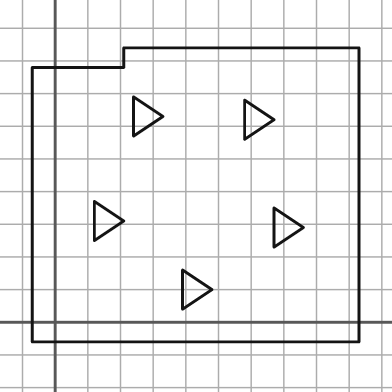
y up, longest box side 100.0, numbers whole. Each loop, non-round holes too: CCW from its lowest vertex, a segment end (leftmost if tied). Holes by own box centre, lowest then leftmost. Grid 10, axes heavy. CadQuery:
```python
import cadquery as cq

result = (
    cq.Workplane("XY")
    .moveTo(-7.0, -6.0)
    .lineTo(93.0, -6.0)
    .lineTo(93.0, 84.0)
    .lineTo(21.0, 84.0)
    .lineTo(21.0, 78.0)
    .lineTo(-7.0, 78.0)
    .close()
    .moveTo(39.0, 4.0)
    .lineTo(48.0, 10.0)
    .lineTo(39.0, 16.0)
    .close()
    .moveTo(67.0, 23.0)
    .lineTo(76.0, 29.0)
    .lineTo(67.0, 35.0)
    .close()
    .moveTo(12.0, 25.0)
    .lineTo(21.0, 31.0)
    .lineTo(12.0, 37.0)
    .close()
    .moveTo(58.0, 56.0)
    .lineTo(67.0, 62.0)
    .lineTo(58.0, 68.0)
    .close()
    .moveTo(24.0, 57.0)
    .lineTo(33.0, 63.0)
    .lineTo(24.0, 69.0)
    .close()
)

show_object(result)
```